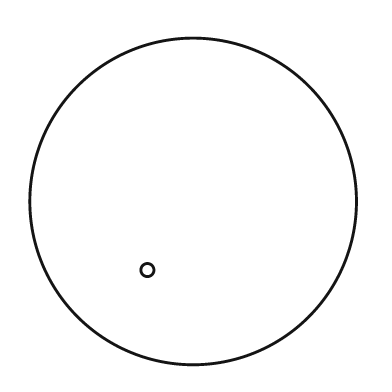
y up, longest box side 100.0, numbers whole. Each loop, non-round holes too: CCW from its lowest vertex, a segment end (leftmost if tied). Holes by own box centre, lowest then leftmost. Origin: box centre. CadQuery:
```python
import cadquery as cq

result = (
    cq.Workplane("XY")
    .moveTo(0.0, 0.0)
    .circle(50.0)
    .moveTo(-14.0, -21.0)
    .circle(2.0)
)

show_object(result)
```